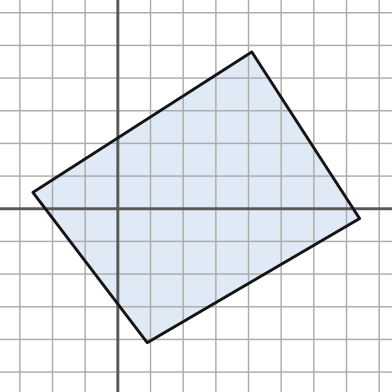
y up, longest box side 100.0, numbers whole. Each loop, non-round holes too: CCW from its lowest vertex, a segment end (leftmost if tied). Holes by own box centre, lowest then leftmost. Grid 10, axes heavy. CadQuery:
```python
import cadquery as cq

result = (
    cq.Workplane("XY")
    .moveTo(9.0, -41.0)
    .lineTo(74.0, -3.0)
    .lineTo(41.0, 48.0)
    .lineTo(-26.0, 5.0)
    .close()
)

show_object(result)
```